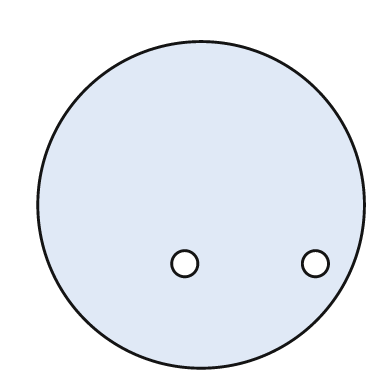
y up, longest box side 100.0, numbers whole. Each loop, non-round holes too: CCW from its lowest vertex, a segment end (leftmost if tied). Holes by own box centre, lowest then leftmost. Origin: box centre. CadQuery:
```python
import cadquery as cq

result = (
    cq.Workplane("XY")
    .moveTo(0.0, 0.0)
    .circle(50.0)
    .moveTo(-5.0, -18.0)
    .circle(4.0)
    .moveTo(35.0, -18.0)
    .circle(4.0)
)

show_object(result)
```